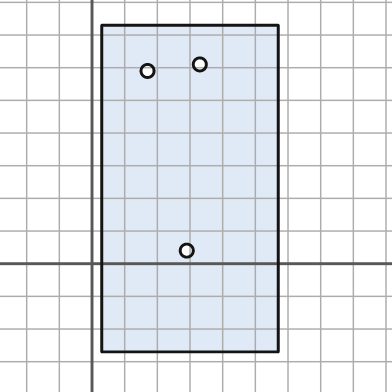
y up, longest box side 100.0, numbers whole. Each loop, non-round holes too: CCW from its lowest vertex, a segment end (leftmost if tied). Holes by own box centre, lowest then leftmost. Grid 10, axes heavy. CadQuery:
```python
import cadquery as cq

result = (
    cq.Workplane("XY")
    .moveTo(3.0, -27.0)
    .lineTo(57.0, -27.0)
    .lineTo(57.0, 73.0)
    .lineTo(3.0, 73.0)
    .close()
    .moveTo(29.0, 4.0)
    .circle(2.0)
    .moveTo(17.0, 59.0)
    .circle(2.0)
    .moveTo(33.0, 61.0)
    .circle(2.0)
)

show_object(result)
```